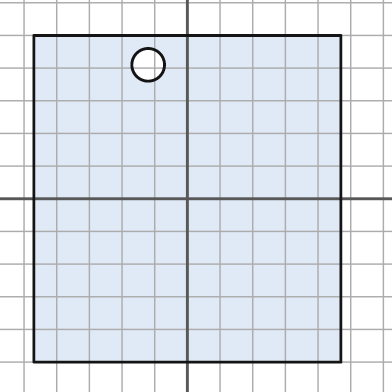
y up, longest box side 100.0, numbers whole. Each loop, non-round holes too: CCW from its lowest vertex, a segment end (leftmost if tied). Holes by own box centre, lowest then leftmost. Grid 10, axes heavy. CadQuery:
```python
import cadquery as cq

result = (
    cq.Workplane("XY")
    .moveTo(-47.0, -50.0)
    .lineTo(47.0, -50.0)
    .lineTo(47.0, 50.0)
    .lineTo(-47.0, 50.0)
    .close()
    .moveTo(-12.0, 41.0)
    .circle(5.0)
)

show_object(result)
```